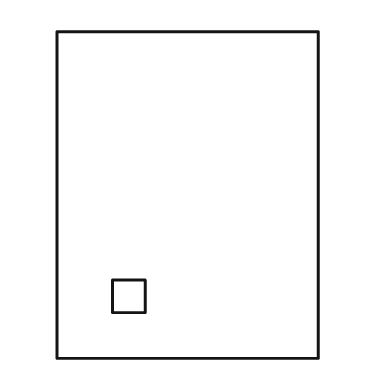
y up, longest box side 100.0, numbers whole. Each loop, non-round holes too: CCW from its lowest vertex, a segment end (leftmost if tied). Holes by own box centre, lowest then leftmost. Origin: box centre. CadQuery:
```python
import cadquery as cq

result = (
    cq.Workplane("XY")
    .moveTo(-40.0, -50.0)
    .lineTo(40.0, -50.0)
    .lineTo(40.0, 50.0)
    .lineTo(-40.0, 50.0)
    .close()
    .moveTo(-23.0, -36.0)
    .lineTo(-13.0, -36.0)
    .lineTo(-13.0, -26.0)
    .lineTo(-23.0, -26.0)
    .close()
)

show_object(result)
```